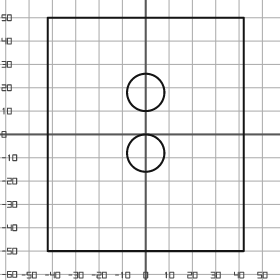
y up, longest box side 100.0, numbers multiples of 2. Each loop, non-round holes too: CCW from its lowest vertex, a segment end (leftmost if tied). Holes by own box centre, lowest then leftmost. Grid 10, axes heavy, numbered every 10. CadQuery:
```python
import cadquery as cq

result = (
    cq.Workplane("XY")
    .moveTo(-42.0, -50.0)
    .lineTo(42.0, -50.0)
    .lineTo(42.0, 50.0)
    .lineTo(-42.0, 50.0)
    .close()
    .moveTo(0.0, -8.0)
    .circle(8.0)
    .moveTo(0.0, 18.0)
    .circle(8.0)
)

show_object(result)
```